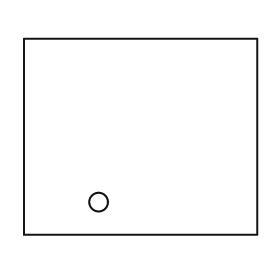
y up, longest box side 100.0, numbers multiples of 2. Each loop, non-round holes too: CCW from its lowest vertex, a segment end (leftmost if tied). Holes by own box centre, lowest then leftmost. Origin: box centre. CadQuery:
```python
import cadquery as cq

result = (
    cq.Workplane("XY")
    .moveTo(-50.0, -42.0)
    .lineTo(50.0, -42.0)
    .lineTo(50.0, 42.0)
    .lineTo(-50.0, 42.0)
    .close()
    .moveTo(-18.0, -28.0)
    .circle(4.0)
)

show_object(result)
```